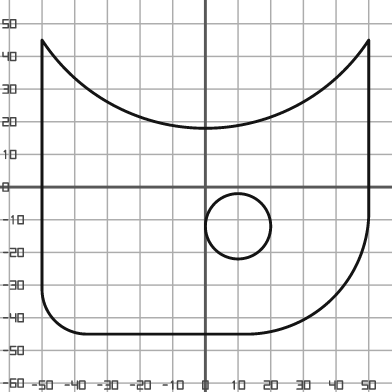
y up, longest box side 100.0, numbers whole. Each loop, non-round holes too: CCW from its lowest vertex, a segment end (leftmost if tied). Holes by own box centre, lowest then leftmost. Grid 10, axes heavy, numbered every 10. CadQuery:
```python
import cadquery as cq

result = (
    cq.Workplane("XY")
    .moveTo(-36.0, -45.0)
    .lineTo(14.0, -45.0)
    .threePointArc((39.0, -34.0), (50.0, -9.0))
    .lineTo(50.0, 45.0)
    .threePointArc((0.0, 18.0), (-50.0, 45.0))
    .lineTo(-50.0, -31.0)
    .threePointArc((-46.0, -41.0), (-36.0, -45.0))
    .close()
    .moveTo(10.0, -12.0)
    .circle(10.0)
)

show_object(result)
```